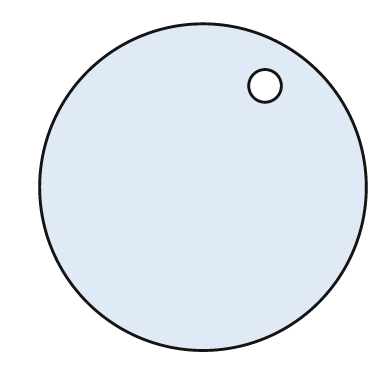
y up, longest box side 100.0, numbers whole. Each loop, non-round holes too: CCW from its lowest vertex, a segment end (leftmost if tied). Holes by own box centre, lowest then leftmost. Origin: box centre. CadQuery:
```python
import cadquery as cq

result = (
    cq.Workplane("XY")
    .moveTo(0.0, 0.0)
    .circle(50.0)
    .moveTo(19.0, 31.0)
    .circle(5.0)
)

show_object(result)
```